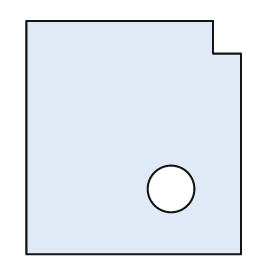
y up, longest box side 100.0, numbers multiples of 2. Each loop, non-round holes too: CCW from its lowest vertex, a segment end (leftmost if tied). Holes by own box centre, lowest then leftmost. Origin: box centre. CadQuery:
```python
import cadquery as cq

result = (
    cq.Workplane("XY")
    .moveTo(-46.0, -50.0)
    .lineTo(46.0, -50.0)
    .lineTo(46.0, 36.0)
    .lineTo(34.0, 36.0)
    .lineTo(34.0, 50.0)
    .lineTo(-46.0, 50.0)
    .close()
    .moveTo(16.0, -22.0)
    .circle(10.0)
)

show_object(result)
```